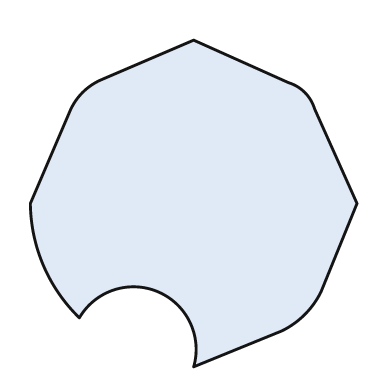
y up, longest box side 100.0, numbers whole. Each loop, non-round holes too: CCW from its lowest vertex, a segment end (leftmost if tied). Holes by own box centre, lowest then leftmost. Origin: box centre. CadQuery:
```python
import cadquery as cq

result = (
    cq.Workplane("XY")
    .moveTo(0.0, -50.0)
    .lineTo(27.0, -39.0)
    .threePointArc((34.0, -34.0), (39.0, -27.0))
    .lineTo(50.0, 0.0)
    .lineTo(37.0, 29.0)
    .threePointArc((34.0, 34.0), (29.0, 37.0))
    .lineTo(0.0, 50.0)
    .lineTo(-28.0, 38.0)
    .threePointArc((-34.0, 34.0), (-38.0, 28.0))
    .lineTo(-50.0, 0.0)
    .threePointArc((-46.0, -19.0), (-35.0, -35.0))
    .threePointArc((-11.0, -27.0), (0.0, -50.0))
    .close()
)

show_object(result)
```